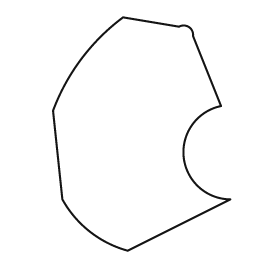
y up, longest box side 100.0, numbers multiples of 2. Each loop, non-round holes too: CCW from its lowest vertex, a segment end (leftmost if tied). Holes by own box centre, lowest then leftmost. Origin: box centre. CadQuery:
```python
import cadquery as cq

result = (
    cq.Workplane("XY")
    .moveTo(-6.0, -50.0)
    .lineTo(38.0, -28.0)
    .threePointArc((18.0, -10.0), (34.0, 12.0))
    .lineTo(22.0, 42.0)
    .threePointArc((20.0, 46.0), (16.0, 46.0))
    .lineTo(-8.0, 50.0)
    .threePointArc((-26.0, 32.0), (-38.0, 10.0))
    .lineTo(-34.0, -28.0)
    .threePointArc((-22.0, -42.0), (-6.0, -50.0))
    .close()
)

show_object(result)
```